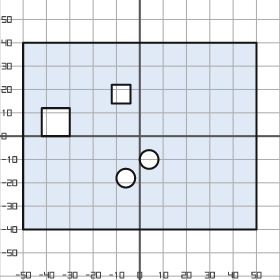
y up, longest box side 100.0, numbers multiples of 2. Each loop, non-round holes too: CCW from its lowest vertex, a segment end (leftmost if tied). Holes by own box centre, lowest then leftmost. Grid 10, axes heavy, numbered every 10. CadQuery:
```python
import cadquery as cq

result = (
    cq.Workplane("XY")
    .moveTo(-50.0, -40.0)
    .lineTo(50.0, -40.0)
    .lineTo(50.0, 40.0)
    .lineTo(-50.0, 40.0)
    .close()
    .moveTo(-6.0, -18.0)
    .circle(4.0)
    .moveTo(4.0, -10.0)
    .circle(4.0)
    .moveTo(-42.0, 0.0)
    .lineTo(-30.0, 0.0)
    .lineTo(-30.0, 12.0)
    .lineTo(-42.0, 12.0)
    .close()
    .moveTo(-12.0, 14.0)
    .lineTo(-4.0, 14.0)
    .lineTo(-4.0, 22.0)
    .lineTo(-12.0, 22.0)
    .close()
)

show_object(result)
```